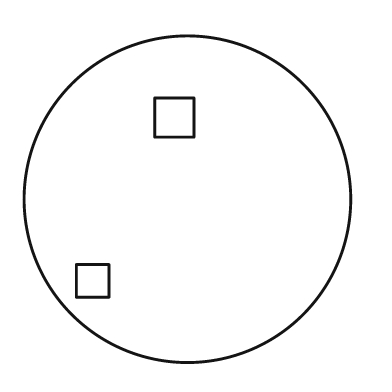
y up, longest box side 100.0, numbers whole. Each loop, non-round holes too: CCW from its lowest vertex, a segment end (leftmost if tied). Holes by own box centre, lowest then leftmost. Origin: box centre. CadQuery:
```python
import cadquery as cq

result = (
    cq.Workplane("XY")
    .moveTo(0.0, 0.0)
    .circle(50.0)
    .moveTo(-34.0, -30.0)
    .lineTo(-24.0, -30.0)
    .lineTo(-24.0, -20.0)
    .lineTo(-34.0, -20.0)
    .close()
    .moveTo(-10.0, 19.0)
    .lineTo(2.0, 19.0)
    .lineTo(2.0, 31.0)
    .lineTo(-10.0, 31.0)
    .close()
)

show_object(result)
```